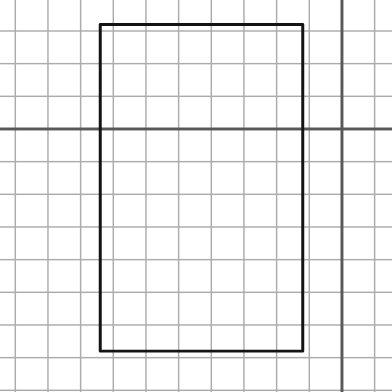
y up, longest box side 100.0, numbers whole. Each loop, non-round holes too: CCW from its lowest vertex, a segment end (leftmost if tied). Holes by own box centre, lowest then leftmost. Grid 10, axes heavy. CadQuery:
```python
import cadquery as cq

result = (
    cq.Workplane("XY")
    .moveTo(-74.0, -68.0)
    .lineTo(-12.0, -68.0)
    .lineTo(-12.0, 32.0)
    .lineTo(-74.0, 32.0)
    .close()
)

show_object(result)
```